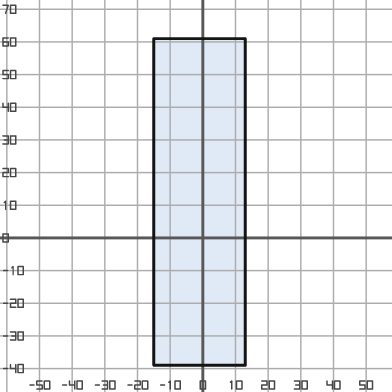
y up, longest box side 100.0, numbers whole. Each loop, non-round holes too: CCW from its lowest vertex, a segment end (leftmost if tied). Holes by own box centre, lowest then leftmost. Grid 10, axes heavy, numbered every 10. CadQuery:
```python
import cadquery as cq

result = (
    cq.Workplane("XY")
    .moveTo(-15.0, -39.0)
    .lineTo(13.0, -39.0)
    .lineTo(13.0, 61.0)
    .lineTo(-15.0, 61.0)
    .close()
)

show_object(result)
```